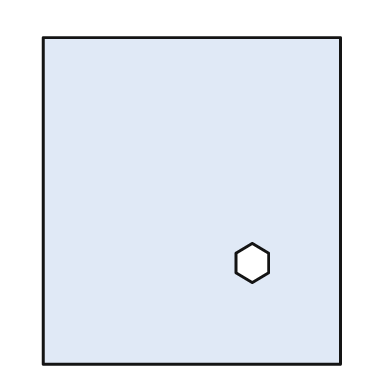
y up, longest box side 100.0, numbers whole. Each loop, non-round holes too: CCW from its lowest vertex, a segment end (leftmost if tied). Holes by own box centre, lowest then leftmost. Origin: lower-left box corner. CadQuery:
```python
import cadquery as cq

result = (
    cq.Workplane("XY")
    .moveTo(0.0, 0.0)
    .lineTo(91.0, 0.0)
    .lineTo(91.0, 100.0)
    .lineTo(0.0, 100.0)
    .close()
    .moveTo(64.0, 25.0)
    .lineTo(69.0, 28.0)
    .lineTo(69.0, 34.0)
    .lineTo(64.0, 37.0)
    .lineTo(59.0, 34.0)
    .lineTo(59.0, 28.0)
    .close()
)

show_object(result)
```